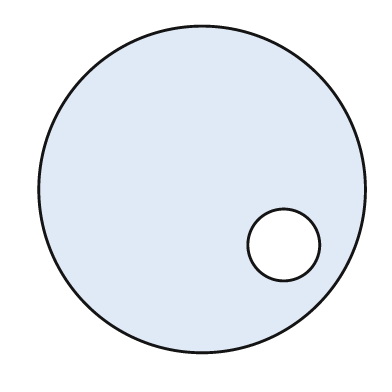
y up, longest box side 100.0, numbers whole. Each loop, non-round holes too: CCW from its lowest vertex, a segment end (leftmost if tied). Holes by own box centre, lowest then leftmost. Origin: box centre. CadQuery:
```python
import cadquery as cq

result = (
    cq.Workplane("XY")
    .moveTo(0.0, 0.0)
    .circle(50.0)
    .moveTo(25.0, -17.0)
    .circle(11.0)
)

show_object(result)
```